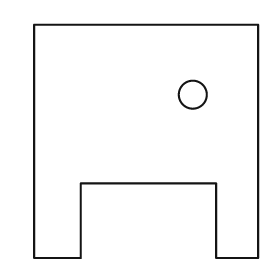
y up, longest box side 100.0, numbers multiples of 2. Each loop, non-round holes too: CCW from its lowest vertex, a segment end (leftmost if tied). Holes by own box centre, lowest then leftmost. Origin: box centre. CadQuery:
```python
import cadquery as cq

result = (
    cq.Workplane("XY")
    .moveTo(-48.0, -50.0)
    .lineTo(-28.0, -50.0)
    .lineTo(-28.0, -18.0)
    .lineTo(30.0, -18.0)
    .lineTo(30.0, -50.0)
    .lineTo(48.0, -50.0)
    .lineTo(48.0, 50.0)
    .lineTo(-48.0, 50.0)
    .close()
    .moveTo(20.0, 20.0)
    .circle(6.0)
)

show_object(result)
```